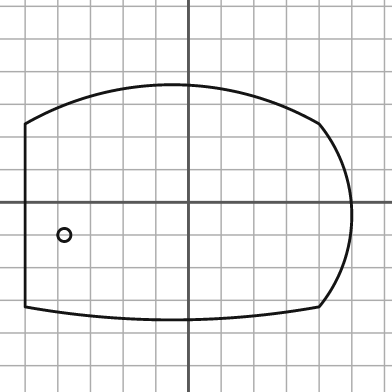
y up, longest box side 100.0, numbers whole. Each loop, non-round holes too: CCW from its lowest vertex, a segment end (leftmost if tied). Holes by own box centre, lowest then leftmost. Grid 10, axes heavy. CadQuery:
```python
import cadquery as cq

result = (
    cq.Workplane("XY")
    .moveTo(-50.0, -32.0)
    .threePointArc((-5.0, -36.0), (40.0, -32.0))
    .threePointArc((50.0, -4.0), (40.0, 24.0))
    .threePointArc((-5.0, 36.0), (-50.0, 24.0))
    .close()
    .moveTo(-38.0, -10.0)
    .circle(2.0)
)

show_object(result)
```